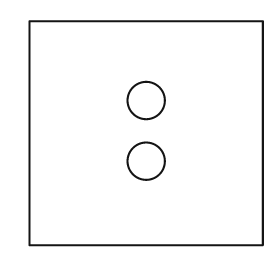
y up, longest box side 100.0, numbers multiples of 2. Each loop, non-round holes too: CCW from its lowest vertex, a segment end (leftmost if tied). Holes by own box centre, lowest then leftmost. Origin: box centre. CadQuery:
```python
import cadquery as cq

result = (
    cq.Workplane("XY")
    .moveTo(-50.0, -48.0)
    .lineTo(50.0, -48.0)
    .lineTo(50.0, 48.0)
    .lineTo(-50.0, 48.0)
    .close()
    .moveTo(0.0, -12.0)
    .circle(8.0)
    .moveTo(0.0, 14.0)
    .circle(8.0)
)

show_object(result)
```